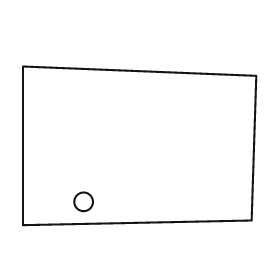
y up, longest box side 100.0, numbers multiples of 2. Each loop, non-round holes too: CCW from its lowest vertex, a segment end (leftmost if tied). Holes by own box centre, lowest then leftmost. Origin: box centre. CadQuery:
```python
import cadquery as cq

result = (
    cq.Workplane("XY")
    .moveTo(-50.0, -34.0)
    .lineTo(48.0, -32.0)
    .lineTo(50.0, 30.0)
    .lineTo(-50.0, 34.0)
    .close()
    .moveTo(-24.0, -24.0)
    .circle(4.0)
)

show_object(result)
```